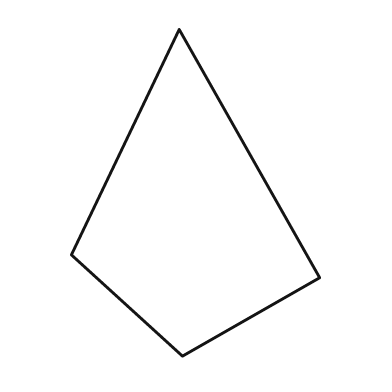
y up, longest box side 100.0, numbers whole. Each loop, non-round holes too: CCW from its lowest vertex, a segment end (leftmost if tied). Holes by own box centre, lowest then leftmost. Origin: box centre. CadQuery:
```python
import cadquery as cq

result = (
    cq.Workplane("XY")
    .moveTo(-4.0, -50.0)
    .lineTo(38.0, -26.0)
    .lineTo(-5.0, 50.0)
    .lineTo(-38.0, -19.0)
    .close()
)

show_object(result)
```